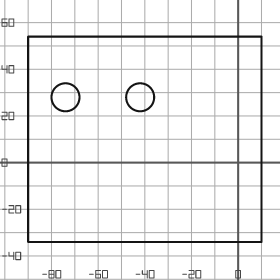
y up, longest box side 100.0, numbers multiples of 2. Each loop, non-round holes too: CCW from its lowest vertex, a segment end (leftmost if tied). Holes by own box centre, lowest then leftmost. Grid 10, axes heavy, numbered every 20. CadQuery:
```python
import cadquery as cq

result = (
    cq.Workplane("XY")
    .moveTo(-90.0, -34.0)
    .lineTo(10.0, -34.0)
    .lineTo(10.0, 54.0)
    .lineTo(-90.0, 54.0)
    .close()
    .moveTo(-74.0, 28.0)
    .circle(6.0)
    .moveTo(-42.0, 28.0)
    .circle(6.0)
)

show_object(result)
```